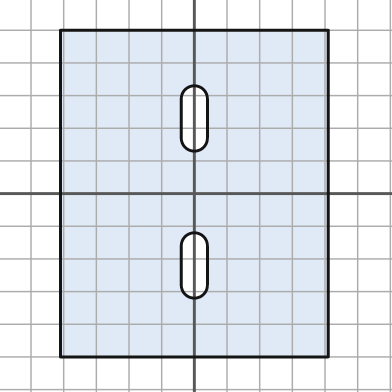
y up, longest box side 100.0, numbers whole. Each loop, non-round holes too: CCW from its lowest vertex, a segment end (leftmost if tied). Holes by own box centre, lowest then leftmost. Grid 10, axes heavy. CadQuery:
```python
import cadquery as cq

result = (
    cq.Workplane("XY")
    .moveTo(-41.0, -50.0)
    .lineTo(41.0, -50.0)
    .lineTo(41.0, 50.0)
    .lineTo(-41.0, 50.0)
    .close()
    .moveTo(-4.0, -28.0)
    .threePointArc((0.0, -32.0), (4.0, -28.0))
    .lineTo(4.0, -16.0)
    .threePointArc((0.0, -12.0), (-4.0, -16.0))
    .close()
    .moveTo(-4.0, 17.0)
    .threePointArc((0.0, 13.0), (4.0, 17.0))
    .lineTo(4.0, 29.0)
    .threePointArc((0.0, 33.0), (-4.0, 29.0))
    .close()
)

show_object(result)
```